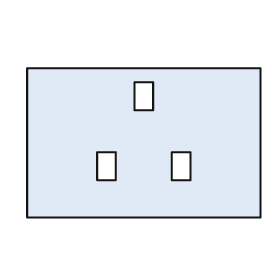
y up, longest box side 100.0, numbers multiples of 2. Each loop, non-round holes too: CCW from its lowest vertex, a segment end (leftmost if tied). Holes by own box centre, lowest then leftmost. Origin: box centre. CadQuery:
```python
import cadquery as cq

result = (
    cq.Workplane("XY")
    .moveTo(-50.0, -32.0)
    .lineTo(50.0, -32.0)
    .lineTo(50.0, 32.0)
    .lineTo(-50.0, 32.0)
    .close()
    .moveTo(-20.0, -16.0)
    .lineTo(-12.0, -16.0)
    .lineTo(-12.0, -4.0)
    .lineTo(-20.0, -4.0)
    .close()
    .moveTo(12.0, -16.0)
    .lineTo(20.0, -16.0)
    .lineTo(20.0, -4.0)
    .lineTo(12.0, -4.0)
    .close()
    .moveTo(-4.0, 14.0)
    .lineTo(4.0, 14.0)
    .lineTo(4.0, 26.0)
    .lineTo(-4.0, 26.0)
    .close()
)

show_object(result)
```